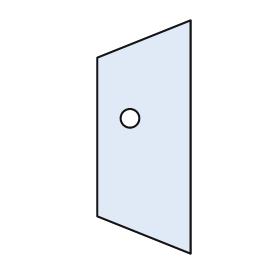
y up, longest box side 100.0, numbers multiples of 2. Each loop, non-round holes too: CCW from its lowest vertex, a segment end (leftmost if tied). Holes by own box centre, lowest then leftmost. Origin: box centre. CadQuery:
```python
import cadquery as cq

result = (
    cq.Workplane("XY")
    .moveTo(20.0, -50.0)
    .lineTo(20.0, 50.0)
    .lineTo(-20.0, 34.0)
    .lineTo(-20.0, -34.0)
    .close()
    .moveTo(-6.0, 8.0)
    .circle(4.0)
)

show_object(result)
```